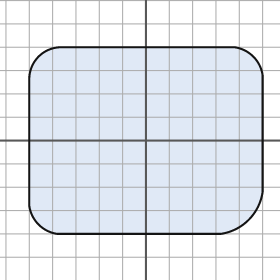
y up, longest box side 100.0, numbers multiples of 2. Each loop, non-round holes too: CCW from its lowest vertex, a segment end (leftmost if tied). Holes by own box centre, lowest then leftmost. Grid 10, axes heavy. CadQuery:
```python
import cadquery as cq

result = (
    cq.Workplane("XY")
    .moveTo(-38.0, -40.0)
    .lineTo(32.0, -40.0)
    .threePointArc((44.0, -34.0), (50.0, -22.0))
    .lineTo(50.0, 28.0)
    .threePointArc((46.0, 36.0), (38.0, 40.0))
    .lineTo(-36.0, 40.0)
    .threePointArc((-46.0, 36.0), (-50.0, 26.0))
    .lineTo(-50.0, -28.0)
    .threePointArc((-46.0, -36.0), (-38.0, -40.0))
    .close()
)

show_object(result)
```